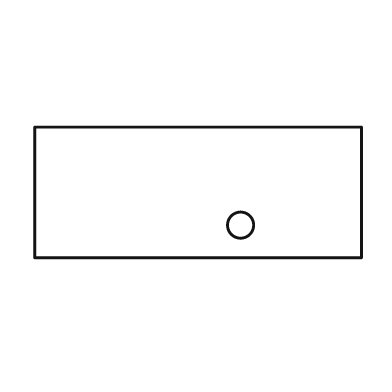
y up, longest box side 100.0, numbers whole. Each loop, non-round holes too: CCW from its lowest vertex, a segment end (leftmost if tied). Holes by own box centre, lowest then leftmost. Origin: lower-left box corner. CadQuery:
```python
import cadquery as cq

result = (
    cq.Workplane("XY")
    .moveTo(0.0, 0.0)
    .lineTo(100.0, 0.0)
    .lineTo(100.0, 40.0)
    .lineTo(0.0, 40.0)
    .close()
    .moveTo(63.0, 10.0)
    .circle(4.0)
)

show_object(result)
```